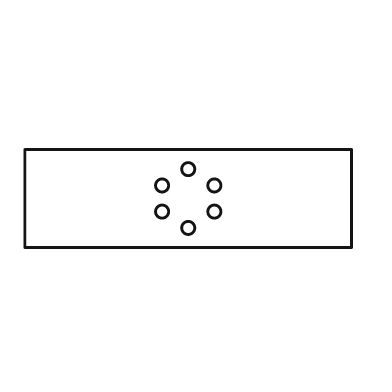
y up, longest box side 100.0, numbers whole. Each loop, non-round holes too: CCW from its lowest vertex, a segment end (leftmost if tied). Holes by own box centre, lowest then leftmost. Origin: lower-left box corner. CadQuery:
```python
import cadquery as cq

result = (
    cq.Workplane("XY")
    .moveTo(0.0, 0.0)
    .lineTo(100.0, 0.0)
    .lineTo(100.0, 30.0)
    .lineTo(0.0, 30.0)
    .close()
    .moveTo(50.0, 6.0)
    .circle(2.0)
    .moveTo(42.0, 11.0)
    .circle(2.0)
    .moveTo(58.0, 11.0)
    .circle(2.0)
    .moveTo(42.0, 19.0)
    .circle(2.0)
    .moveTo(58.0, 19.0)
    .circle(2.0)
    .moveTo(50.0, 24.0)
    .circle(2.0)
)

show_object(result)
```